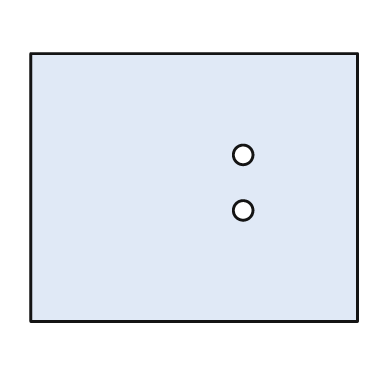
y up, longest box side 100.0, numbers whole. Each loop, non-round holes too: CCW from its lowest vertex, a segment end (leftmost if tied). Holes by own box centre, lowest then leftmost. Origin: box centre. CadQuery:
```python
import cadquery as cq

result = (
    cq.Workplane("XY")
    .moveTo(-50.0, -41.0)
    .lineTo(50.0, -41.0)
    .lineTo(50.0, 41.0)
    .lineTo(-50.0, 41.0)
    .close()
    .moveTo(15.0, -7.0)
    .circle(3.0)
    .moveTo(15.0, 10.0)
    .circle(3.0)
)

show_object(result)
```